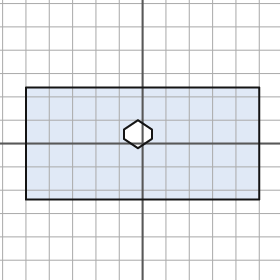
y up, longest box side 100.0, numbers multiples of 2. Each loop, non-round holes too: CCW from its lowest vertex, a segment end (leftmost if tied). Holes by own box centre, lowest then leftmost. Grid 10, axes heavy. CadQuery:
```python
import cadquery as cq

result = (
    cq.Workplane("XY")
    .moveTo(-50.0, -24.0)
    .lineTo(50.0, -24.0)
    .lineTo(50.0, 24.0)
    .lineTo(-50.0, 24.0)
    .close()
    .moveTo(-2.0, -2.0)
    .lineTo(4.0, 2.0)
    .lineTo(4.0, 6.0)
    .lineTo(-2.0, 10.0)
    .lineTo(-8.0, 6.0)
    .lineTo(-8.0, 2.0)
    .close()
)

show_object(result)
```